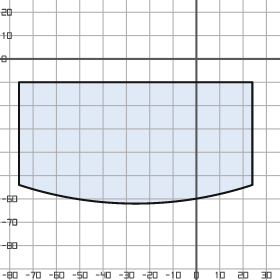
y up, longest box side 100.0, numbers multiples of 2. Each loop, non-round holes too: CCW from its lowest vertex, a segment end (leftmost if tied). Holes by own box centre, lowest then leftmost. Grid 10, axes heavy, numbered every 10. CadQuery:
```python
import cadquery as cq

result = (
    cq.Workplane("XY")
    .moveTo(-76.0, -54.0)
    .threePointArc((-26.0, -62.0), (24.0, -54.0))
    .lineTo(24.0, -10.0)
    .lineTo(-76.0, -10.0)
    .close()
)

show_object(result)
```